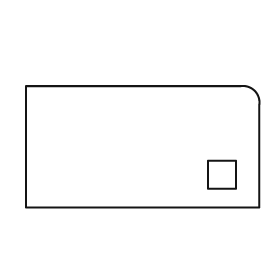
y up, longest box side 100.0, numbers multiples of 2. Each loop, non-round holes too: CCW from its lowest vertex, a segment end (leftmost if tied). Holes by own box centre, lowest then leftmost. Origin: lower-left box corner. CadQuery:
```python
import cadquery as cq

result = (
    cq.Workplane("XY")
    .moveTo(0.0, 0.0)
    .lineTo(100.0, 0.0)
    .lineTo(100.0, 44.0)
    .threePointArc((98.0, 50.0), (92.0, 52.0))
    .lineTo(0.0, 52.0)
    .close()
    .moveTo(78.0, 8.0)
    .lineTo(90.0, 8.0)
    .lineTo(90.0, 20.0)
    .lineTo(78.0, 20.0)
    .close()
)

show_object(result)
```